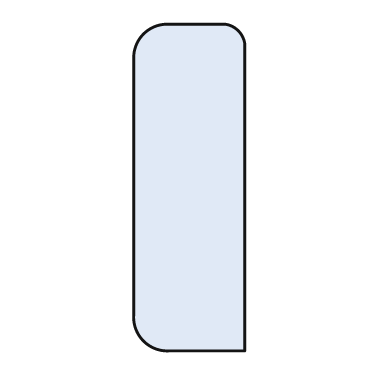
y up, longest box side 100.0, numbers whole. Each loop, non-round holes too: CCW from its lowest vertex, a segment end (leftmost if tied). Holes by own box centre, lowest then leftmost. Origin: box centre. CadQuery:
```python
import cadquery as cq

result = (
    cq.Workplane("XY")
    .moveTo(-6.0, -50.0)
    .lineTo(17.0, -50.0)
    .lineTo(17.0, 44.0)
    .threePointArc((15.0, 48.0), (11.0, 50.0))
    .lineTo(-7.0, 50.0)
    .threePointArc((-14.0, 47.0), (-17.0, 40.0))
    .lineTo(-17.0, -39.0)
    .threePointArc((-14.0, -47.0), (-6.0, -50.0))
    .close()
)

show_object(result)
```